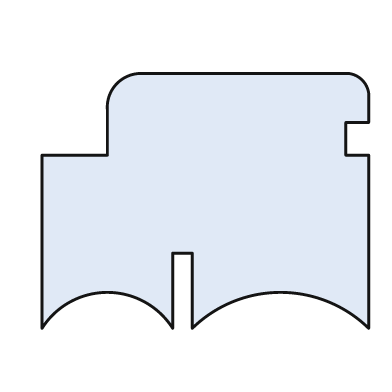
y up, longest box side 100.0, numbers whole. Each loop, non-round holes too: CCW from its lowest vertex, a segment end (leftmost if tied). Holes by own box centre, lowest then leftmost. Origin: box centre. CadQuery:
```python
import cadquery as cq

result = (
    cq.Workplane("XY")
    .moveTo(-50.0, -39.0)
    .threePointArc((-30.0, -28.0), (-10.0, -39.0))
    .lineTo(-10.0, -16.0)
    .lineTo(-4.0, -16.0)
    .lineTo(-4.0, -39.0)
    .threePointArc((23.0, -28.0), (50.0, -39.0))
    .lineTo(50.0, 14.0)
    .lineTo(43.0, 14.0)
    .lineTo(43.0, 24.0)
    .lineTo(50.0, 24.0)
    .lineTo(50.0, 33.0)
    .threePointArc((48.0, 37.0), (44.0, 39.0))
    .lineTo(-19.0, 39.0)
    .threePointArc((-27.0, 36.0), (-30.0, 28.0))
    .lineTo(-30.0, 14.0)
    .lineTo(-50.0, 14.0)
    .close()
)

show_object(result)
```